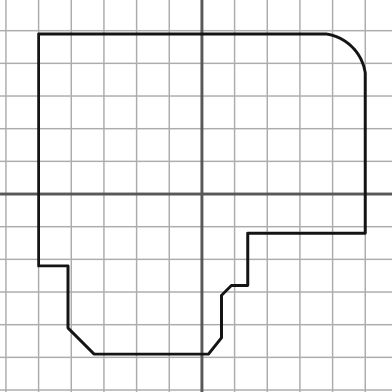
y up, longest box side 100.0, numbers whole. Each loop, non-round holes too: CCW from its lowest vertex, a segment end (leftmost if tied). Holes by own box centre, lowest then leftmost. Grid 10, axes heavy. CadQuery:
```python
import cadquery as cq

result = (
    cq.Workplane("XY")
    .moveTo(-33.0, -49.0)
    .lineTo(2.0, -49.0)
    .lineTo(6.0, -44.0)
    .lineTo(6.0, -31.0)
    .lineTo(9.0, -28.0)
    .lineTo(14.0, -28.0)
    .lineTo(14.0, -12.0)
    .lineTo(50.0, -12.0)
    .lineTo(50.0, 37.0)
    .threePointArc((46.0, 45.0), (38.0, 49.0))
    .lineTo(-50.0, 49.0)
    .lineTo(-50.0, -22.0)
    .lineTo(-41.0, -22.0)
    .lineTo(-41.0, -41.0)
    .close()
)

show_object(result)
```